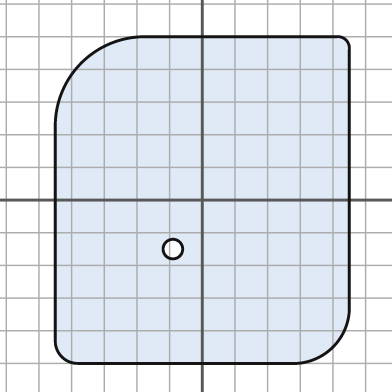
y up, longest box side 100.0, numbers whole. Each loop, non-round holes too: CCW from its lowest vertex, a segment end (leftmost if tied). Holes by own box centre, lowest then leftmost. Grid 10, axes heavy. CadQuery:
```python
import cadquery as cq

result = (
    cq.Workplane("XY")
    .moveTo(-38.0, -50.0)
    .lineTo(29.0, -50.0)
    .threePointArc((40.0, -45.0), (45.0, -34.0))
    .lineTo(45.0, 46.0)
    .threePointArc((44.0, 49.0), (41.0, 50.0))
    .lineTo(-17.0, 50.0)
    .threePointArc((-37.0, 42.0), (-45.0, 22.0))
    .lineTo(-45.0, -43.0)
    .threePointArc((-43.0, -48.0), (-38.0, -50.0))
    .close()
    .moveTo(-9.0, -15.0)
    .circle(3.0)
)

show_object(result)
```